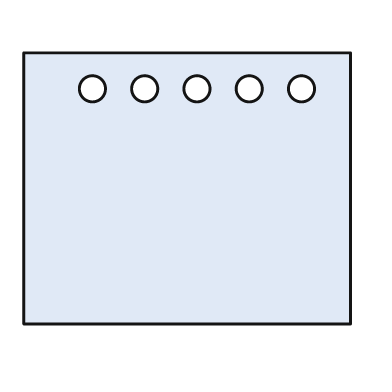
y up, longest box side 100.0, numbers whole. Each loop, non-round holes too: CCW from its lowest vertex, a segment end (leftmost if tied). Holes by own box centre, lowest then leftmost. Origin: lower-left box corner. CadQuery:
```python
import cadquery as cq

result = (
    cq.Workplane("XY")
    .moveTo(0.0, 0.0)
    .lineTo(100.0, 0.0)
    .lineTo(100.0, 83.0)
    .lineTo(0.0, 83.0)
    .close()
    .moveTo(21.0, 72.0)
    .circle(4.0)
    .moveTo(37.0, 72.0)
    .circle(4.0)
    .moveTo(53.0, 72.0)
    .circle(4.0)
    .moveTo(69.0, 72.0)
    .circle(4.0)
    .moveTo(85.0, 72.0)
    .circle(4.0)
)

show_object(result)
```